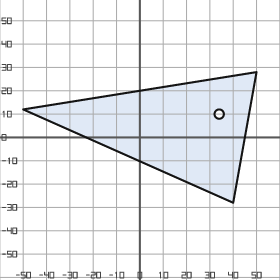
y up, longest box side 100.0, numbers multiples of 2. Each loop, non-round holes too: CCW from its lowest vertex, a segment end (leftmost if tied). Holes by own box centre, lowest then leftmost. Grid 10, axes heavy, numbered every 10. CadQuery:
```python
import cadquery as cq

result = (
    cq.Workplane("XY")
    .moveTo(40.0, -28.0)
    .lineTo(50.0, 28.0)
    .lineTo(-50.0, 12.0)
    .close()
    .moveTo(34.0, 10.0)
    .circle(2.0)
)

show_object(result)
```